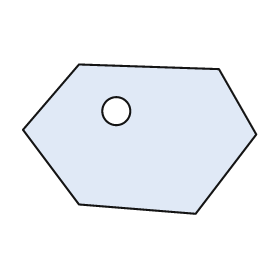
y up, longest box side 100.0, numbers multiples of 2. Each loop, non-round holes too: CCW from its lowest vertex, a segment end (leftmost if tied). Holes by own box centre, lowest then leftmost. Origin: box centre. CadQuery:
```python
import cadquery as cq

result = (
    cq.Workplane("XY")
    .moveTo(24.0, -32.0)
    .lineTo(50.0, 2.0)
    .lineTo(34.0, 30.0)
    .lineTo(-26.0, 32.0)
    .lineTo(-50.0, 4.0)
    .lineTo(-26.0, -28.0)
    .close()
    .moveTo(-10.0, 12.0)
    .circle(6.0)
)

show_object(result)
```